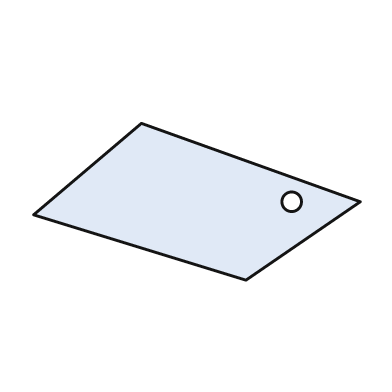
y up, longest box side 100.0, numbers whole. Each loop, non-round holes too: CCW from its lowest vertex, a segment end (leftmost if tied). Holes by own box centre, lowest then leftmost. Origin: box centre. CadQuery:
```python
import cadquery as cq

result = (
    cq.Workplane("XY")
    .moveTo(15.0, -24.0)
    .lineTo(50.0, 0.0)
    .lineTo(-17.0, 24.0)
    .lineTo(-50.0, -4.0)
    .close()
    .moveTo(29.0, 0.0)
    .circle(3.0)
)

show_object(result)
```